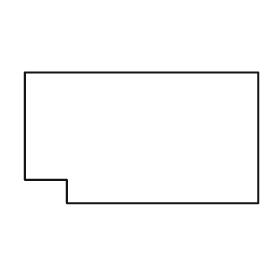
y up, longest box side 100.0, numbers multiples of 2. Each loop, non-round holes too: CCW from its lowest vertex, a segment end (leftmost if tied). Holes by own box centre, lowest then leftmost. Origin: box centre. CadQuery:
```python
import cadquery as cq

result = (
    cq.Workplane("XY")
    .moveTo(-32.0, -28.0)
    .lineTo(50.0, -28.0)
    .lineTo(50.0, 28.0)
    .lineTo(-50.0, 28.0)
    .lineTo(-50.0, -18.0)
    .lineTo(-32.0, -18.0)
    .close()
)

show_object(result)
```